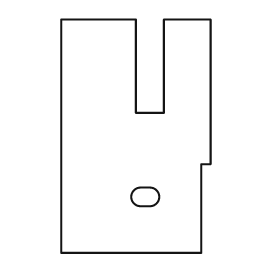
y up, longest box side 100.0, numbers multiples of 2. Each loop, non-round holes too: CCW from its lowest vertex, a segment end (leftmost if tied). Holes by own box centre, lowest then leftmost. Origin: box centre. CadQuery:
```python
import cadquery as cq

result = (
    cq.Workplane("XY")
    .moveTo(-32.0, -50.0)
    .lineTo(28.0, -50.0)
    .lineTo(28.0, -12.0)
    .lineTo(32.0, -12.0)
    .lineTo(32.0, 50.0)
    .lineTo(12.0, 50.0)
    .lineTo(12.0, 10.0)
    .lineTo(0.0, 10.0)
    .lineTo(0.0, 50.0)
    .lineTo(-32.0, 50.0)
    .close()
    .moveTo(2.0, -30.0)
    .lineTo(6.0, -30.0)
    .threePointArc((10.0, -26.0), (6.0, -22.0))
    .lineTo(2.0, -22.0)
    .threePointArc((-2.0, -26.0), (2.0, -30.0))
    .close()
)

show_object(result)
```